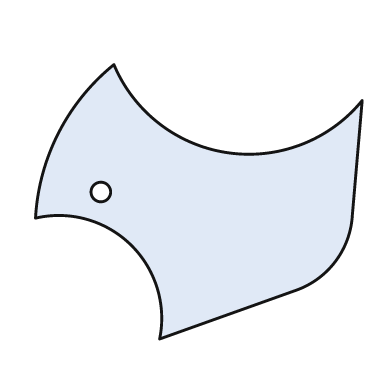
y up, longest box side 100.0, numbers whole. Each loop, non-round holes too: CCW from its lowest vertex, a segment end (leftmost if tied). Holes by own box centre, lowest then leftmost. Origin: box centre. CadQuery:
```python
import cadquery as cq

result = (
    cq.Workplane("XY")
    .moveTo(-12.0, -42.0)
    .lineTo(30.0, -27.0)
    .threePointArc((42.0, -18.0), (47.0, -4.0))
    .lineTo(50.0, 31.0)
    .threePointArc((9.0, 15.0), (-26.0, 42.0))
    .threePointArc((-43.0, 21.0), (-50.0, -5.0))
    .threePointArc((-21.0, -13.0), (-12.0, -42.0))
    .close()
    .moveTo(-30.0, 3.0)
    .circle(3.0)
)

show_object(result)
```